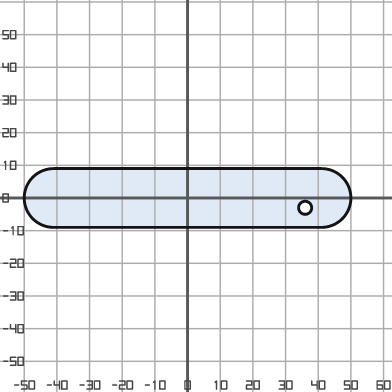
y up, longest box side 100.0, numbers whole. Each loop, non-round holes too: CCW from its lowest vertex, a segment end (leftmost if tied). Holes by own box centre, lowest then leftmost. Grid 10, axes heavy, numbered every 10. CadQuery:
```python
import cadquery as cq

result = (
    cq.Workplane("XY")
    .moveTo(-41.0, -9.0)
    .lineTo(41.0, -9.0)
    .threePointArc((50.0, 0.0), (41.0, 9.0))
    .lineTo(-41.0, 9.0)
    .threePointArc((-50.0, 0.0), (-41.0, -9.0))
    .close()
    .moveTo(36.0, -3.0)
    .circle(2.0)
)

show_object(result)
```